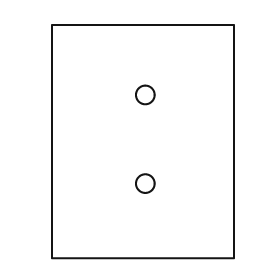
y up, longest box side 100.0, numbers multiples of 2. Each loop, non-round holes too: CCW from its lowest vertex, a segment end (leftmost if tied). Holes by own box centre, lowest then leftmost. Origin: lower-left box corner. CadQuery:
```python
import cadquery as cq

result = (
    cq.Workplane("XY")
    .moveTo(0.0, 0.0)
    .lineTo(78.0, 0.0)
    .lineTo(78.0, 100.0)
    .lineTo(0.0, 100.0)
    .close()
    .moveTo(40.0, 32.0)
    .circle(4.0)
    .moveTo(40.0, 70.0)
    .circle(4.0)
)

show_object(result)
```